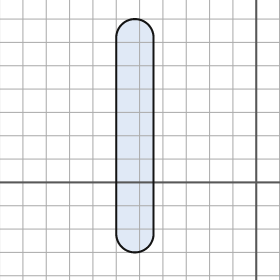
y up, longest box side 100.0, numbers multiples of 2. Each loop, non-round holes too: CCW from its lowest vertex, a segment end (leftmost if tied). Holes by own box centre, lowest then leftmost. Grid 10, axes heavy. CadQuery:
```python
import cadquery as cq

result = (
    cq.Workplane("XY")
    .moveTo(-60.0, -22.0)
    .threePointArc((-52.0, -30.0), (-44.0, -22.0))
    .lineTo(-44.0, 62.0)
    .threePointArc((-52.0, 70.0), (-60.0, 62.0))
    .close()
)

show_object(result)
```